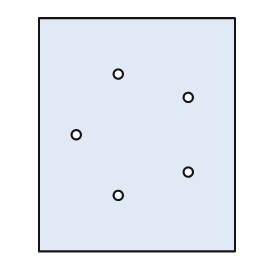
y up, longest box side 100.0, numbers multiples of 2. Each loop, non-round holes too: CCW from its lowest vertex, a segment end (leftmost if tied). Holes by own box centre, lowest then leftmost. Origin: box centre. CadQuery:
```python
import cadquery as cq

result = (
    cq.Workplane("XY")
    .moveTo(-42.0, -50.0)
    .lineTo(42.0, -50.0)
    .lineTo(42.0, 50.0)
    .lineTo(-42.0, 50.0)
    .close()
    .moveTo(-8.0, -26.0)
    .circle(2.0)
    .moveTo(22.0, -16.0)
    .circle(2.0)
    .moveTo(-26.0, 0.0)
    .circle(2.0)
    .moveTo(22.0, 16.0)
    .circle(2.0)
    .moveTo(-8.0, 26.0)
    .circle(2.0)
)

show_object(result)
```